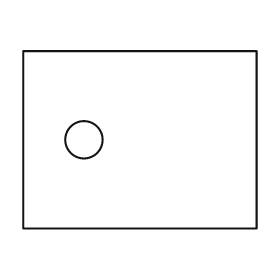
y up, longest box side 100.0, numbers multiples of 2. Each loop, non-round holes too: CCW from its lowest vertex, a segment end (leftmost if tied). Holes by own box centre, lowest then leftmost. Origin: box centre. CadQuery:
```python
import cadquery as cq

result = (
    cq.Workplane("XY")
    .moveTo(-50.0, -38.0)
    .lineTo(50.0, -38.0)
    .lineTo(50.0, 38.0)
    .lineTo(-50.0, 38.0)
    .close()
    .moveTo(-24.0, 0.0)
    .circle(8.0)
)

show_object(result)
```